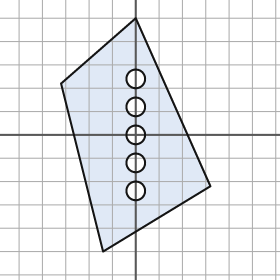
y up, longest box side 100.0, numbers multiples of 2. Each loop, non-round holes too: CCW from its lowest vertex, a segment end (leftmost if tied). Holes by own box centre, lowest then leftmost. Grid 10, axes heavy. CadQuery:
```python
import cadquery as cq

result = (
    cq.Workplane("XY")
    .moveTo(-14.0, -50.0)
    .lineTo(32.0, -22.0)
    .lineTo(0.0, 50.0)
    .lineTo(-32.0, 22.0)
    .close()
    .moveTo(0.0, -24.0)
    .circle(4.0)
    .moveTo(0.0, -12.0)
    .circle(4.0)
    .moveTo(0.0, 0.0)
    .circle(4.0)
    .moveTo(0.0, 12.0)
    .circle(4.0)
    .moveTo(0.0, 24.0)
    .circle(4.0)
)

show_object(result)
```